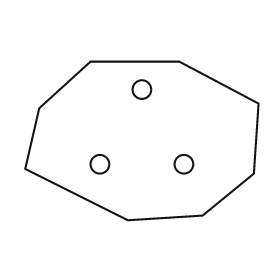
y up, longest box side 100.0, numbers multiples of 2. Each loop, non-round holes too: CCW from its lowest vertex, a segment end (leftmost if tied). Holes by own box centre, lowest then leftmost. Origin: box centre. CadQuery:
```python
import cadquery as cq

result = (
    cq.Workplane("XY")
    .moveTo(-6.0, -34.0)
    .lineTo(26.0, -32.0)
    .lineTo(48.0, -14.0)
    .lineTo(50.0, 16.0)
    .lineTo(16.0, 34.0)
    .lineTo(-22.0, 34.0)
    .lineTo(-44.0, 14.0)
    .lineTo(-50.0, -12.0)
    .close()
    .moveTo(-18.0, -10.0)
    .circle(4.0)
    .moveTo(18.0, -10.0)
    .circle(4.0)
    .moveTo(0.0, 22.0)
    .circle(4.0)
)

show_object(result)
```